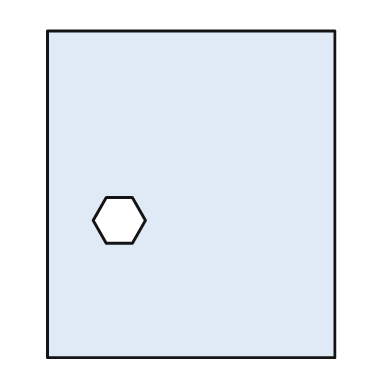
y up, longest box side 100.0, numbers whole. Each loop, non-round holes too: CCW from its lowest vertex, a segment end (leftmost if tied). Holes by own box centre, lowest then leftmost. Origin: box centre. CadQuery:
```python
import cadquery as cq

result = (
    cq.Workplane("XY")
    .moveTo(-44.0, -50.0)
    .lineTo(44.0, -50.0)
    .lineTo(44.0, 50.0)
    .lineTo(-44.0, 50.0)
    .close()
    .moveTo(-26.0, -15.0)
    .lineTo(-18.0, -15.0)
    .lineTo(-14.0, -8.0)
    .lineTo(-18.0, -1.0)
    .lineTo(-26.0, -1.0)
    .lineTo(-30.0, -8.0)
    .close()
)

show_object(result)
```